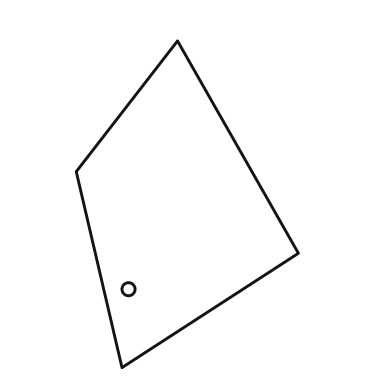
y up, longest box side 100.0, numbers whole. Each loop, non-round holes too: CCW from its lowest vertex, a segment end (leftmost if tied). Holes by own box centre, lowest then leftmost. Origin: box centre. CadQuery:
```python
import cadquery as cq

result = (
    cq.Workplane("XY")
    .moveTo(-20.0, -50.0)
    .lineTo(34.0, -15.0)
    .lineTo(-3.0, 50.0)
    .lineTo(-34.0, 10.0)
    .close()
    .moveTo(-18.0, -26.0)
    .circle(2.0)
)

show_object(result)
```